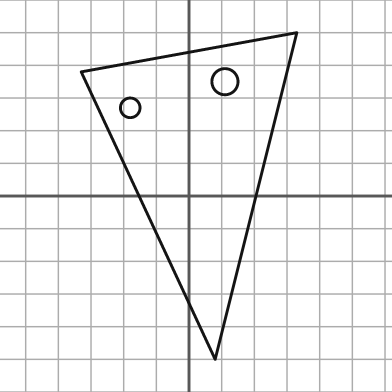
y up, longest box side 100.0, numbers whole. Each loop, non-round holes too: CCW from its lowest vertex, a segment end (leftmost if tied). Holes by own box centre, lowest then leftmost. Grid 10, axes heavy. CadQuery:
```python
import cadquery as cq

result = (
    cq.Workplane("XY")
    .moveTo(8.0, -50.0)
    .lineTo(33.0, 50.0)
    .lineTo(-33.0, 38.0)
    .close()
    .moveTo(-18.0, 27.0)
    .circle(3.0)
    .moveTo(11.0, 35.0)
    .circle(4.0)
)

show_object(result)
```